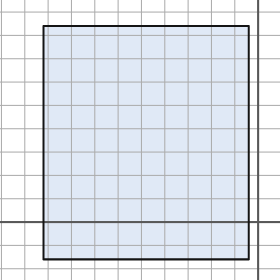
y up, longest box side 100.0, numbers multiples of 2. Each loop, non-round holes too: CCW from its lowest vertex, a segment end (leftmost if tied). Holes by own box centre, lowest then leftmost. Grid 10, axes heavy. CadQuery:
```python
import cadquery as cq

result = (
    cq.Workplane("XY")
    .moveTo(-92.0, -16.0)
    .lineTo(-4.0, -16.0)
    .lineTo(-4.0, 84.0)
    .lineTo(-92.0, 84.0)
    .close()
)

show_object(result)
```